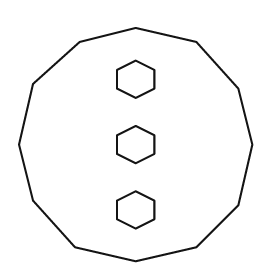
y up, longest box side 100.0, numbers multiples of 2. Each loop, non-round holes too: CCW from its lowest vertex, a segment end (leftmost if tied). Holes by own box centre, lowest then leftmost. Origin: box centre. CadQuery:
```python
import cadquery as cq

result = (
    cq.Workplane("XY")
    .moveTo(0.0, -50.0)
    .lineTo(26.0, -44.0)
    .lineTo(44.0, -26.0)
    .lineTo(50.0, 0.0)
    .lineTo(44.0, 24.0)
    .lineTo(26.0, 44.0)
    .lineTo(0.0, 50.0)
    .lineTo(-24.0, 44.0)
    .lineTo(-44.0, 26.0)
    .lineTo(-50.0, 0.0)
    .lineTo(-44.0, -24.0)
    .lineTo(-26.0, -44.0)
    .close()
    .moveTo(0.0, -36.0)
    .lineTo(8.0, -32.0)
    .lineTo(8.0, -24.0)
    .lineTo(0.0, -20.0)
    .lineTo(-8.0, -24.0)
    .lineTo(-8.0, -32.0)
    .close()
    .moveTo(0.0, -8.0)
    .lineTo(8.0, -4.0)
    .lineTo(8.0, 4.0)
    .lineTo(0.0, 8.0)
    .lineTo(-8.0, 4.0)
    .lineTo(-8.0, -4.0)
    .close()
    .moveTo(0.0, 20.0)
    .lineTo(8.0, 24.0)
    .lineTo(8.0, 32.0)
    .lineTo(0.0, 36.0)
    .lineTo(-8.0, 32.0)
    .lineTo(-8.0, 24.0)
    .close()
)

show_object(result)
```